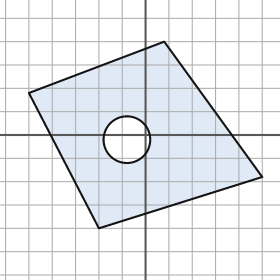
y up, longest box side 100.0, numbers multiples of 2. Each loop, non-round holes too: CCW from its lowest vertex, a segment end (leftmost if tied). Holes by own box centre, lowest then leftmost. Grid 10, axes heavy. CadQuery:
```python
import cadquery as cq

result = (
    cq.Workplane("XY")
    .moveTo(-20.0, -40.0)
    .lineTo(50.0, -18.0)
    .lineTo(8.0, 40.0)
    .lineTo(-50.0, 18.0)
    .close()
    .moveTo(-8.0, -2.0)
    .circle(10.0)
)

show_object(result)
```